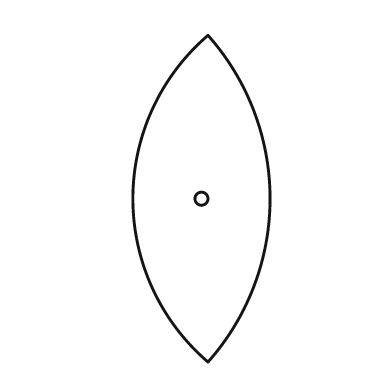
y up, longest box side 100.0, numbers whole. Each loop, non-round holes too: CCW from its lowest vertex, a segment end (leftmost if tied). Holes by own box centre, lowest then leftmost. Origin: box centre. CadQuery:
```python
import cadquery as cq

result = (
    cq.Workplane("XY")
    .moveTo(2.0, -50.0)
    .threePointArc((21.0, 0.0), (2.0, 50.0))
    .threePointArc((-21.0, 0.0), (2.0, -50.0))
    .close()
    .moveTo(0.0, 0.0)
    .circle(2.0)
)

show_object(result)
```